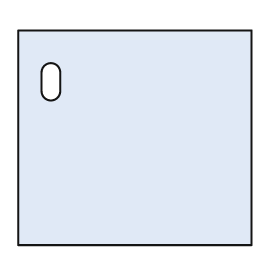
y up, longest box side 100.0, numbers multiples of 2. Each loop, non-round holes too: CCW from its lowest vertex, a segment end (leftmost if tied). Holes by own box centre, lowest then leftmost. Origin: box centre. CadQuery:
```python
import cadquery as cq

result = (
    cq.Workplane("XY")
    .moveTo(-50.0, -46.0)
    .lineTo(50.0, -46.0)
    .lineTo(50.0, 46.0)
    .lineTo(-50.0, 46.0)
    .close()
    .moveTo(-40.0, 20.0)
    .threePointArc((-36.0, 16.0), (-32.0, 20.0))
    .lineTo(-32.0, 28.0)
    .threePointArc((-36.0, 32.0), (-40.0, 28.0))
    .close()
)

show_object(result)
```